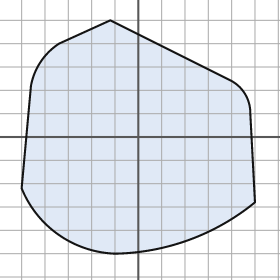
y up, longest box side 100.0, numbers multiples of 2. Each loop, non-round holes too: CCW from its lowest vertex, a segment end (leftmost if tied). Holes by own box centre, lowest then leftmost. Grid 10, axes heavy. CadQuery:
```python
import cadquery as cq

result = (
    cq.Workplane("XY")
    .moveTo(-10.0, -50.0)
    .threePointArc((22.0, -44.0), (50.0, -28.0))
    .lineTo(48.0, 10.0)
    .threePointArc((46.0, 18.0), (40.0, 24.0))
    .lineTo(-12.0, 50.0)
    .lineTo(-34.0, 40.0)
    .threePointArc((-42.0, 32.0), (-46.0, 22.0))
    .lineTo(-50.0, -22.0)
    .threePointArc((-34.0, -42.0), (-10.0, -50.0))
    .close()
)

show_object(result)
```